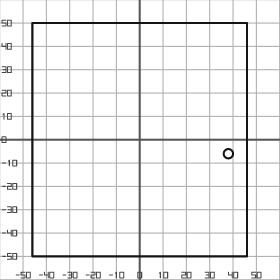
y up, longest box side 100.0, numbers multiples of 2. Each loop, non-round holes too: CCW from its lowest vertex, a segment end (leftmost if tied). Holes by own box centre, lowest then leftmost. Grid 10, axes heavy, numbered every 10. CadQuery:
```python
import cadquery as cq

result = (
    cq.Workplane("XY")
    .moveTo(-46.0, -50.0)
    .lineTo(46.0, -50.0)
    .lineTo(46.0, 50.0)
    .lineTo(-46.0, 50.0)
    .close()
    .moveTo(38.0, -6.0)
    .circle(2.0)
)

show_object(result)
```